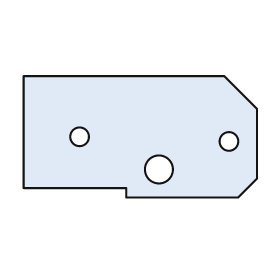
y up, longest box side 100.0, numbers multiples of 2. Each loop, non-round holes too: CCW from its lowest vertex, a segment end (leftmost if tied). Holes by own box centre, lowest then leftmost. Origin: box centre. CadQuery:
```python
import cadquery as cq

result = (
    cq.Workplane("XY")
    .moveTo(-6.0, -26.0)
    .lineTo(42.0, -26.0)
    .lineTo(50.0, -18.0)
    .lineTo(50.0, 12.0)
    .lineTo(36.0, 26.0)
    .lineTo(-50.0, 26.0)
    .lineTo(-50.0, -22.0)
    .lineTo(-6.0, -22.0)
    .close()
    .moveTo(8.0, -14.0)
    .circle(6.0)
    .moveTo(38.0, -2.0)
    .circle(4.0)
    .moveTo(-26.0, 0.0)
    .circle(4.0)
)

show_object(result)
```